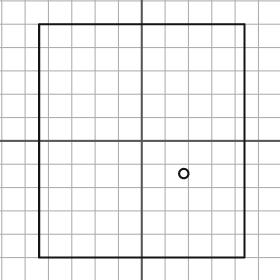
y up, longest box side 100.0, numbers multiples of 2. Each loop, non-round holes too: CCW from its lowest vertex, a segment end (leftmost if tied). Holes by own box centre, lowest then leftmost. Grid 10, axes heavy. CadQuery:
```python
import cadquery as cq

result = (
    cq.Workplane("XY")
    .moveTo(-44.0, -50.0)
    .lineTo(44.0, -50.0)
    .lineTo(44.0, 50.0)
    .lineTo(-44.0, 50.0)
    .close()
    .moveTo(18.0, -14.0)
    .circle(2.0)
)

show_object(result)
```